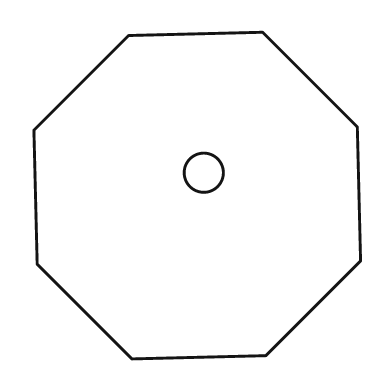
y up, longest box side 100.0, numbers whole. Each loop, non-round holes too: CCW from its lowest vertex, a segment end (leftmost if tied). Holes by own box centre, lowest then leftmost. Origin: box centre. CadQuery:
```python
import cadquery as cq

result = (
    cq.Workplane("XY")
    .moveTo(-20.0, -50.0)
    .lineTo(21.0, -49.0)
    .lineTo(50.0, -20.0)
    .lineTo(49.0, 21.0)
    .lineTo(20.0, 50.0)
    .lineTo(-21.0, 49.0)
    .lineTo(-50.0, 20.0)
    .lineTo(-49.0, -21.0)
    .close()
    .moveTo(2.0, 7.0)
    .circle(6.0)
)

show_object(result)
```